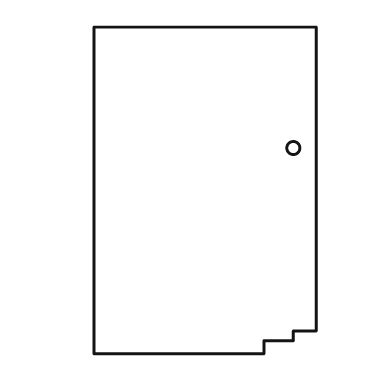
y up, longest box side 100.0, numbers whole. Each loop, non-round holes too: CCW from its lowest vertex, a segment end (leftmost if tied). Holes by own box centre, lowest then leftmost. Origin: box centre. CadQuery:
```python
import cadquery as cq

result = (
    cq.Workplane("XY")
    .moveTo(-34.0, -50.0)
    .lineTo(18.0, -50.0)
    .lineTo(18.0, -46.0)
    .lineTo(27.0, -46.0)
    .lineTo(27.0, -43.0)
    .lineTo(34.0, -43.0)
    .lineTo(34.0, 50.0)
    .lineTo(-34.0, 50.0)
    .close()
    .moveTo(27.0, 13.0)
    .circle(2.0)
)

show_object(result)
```